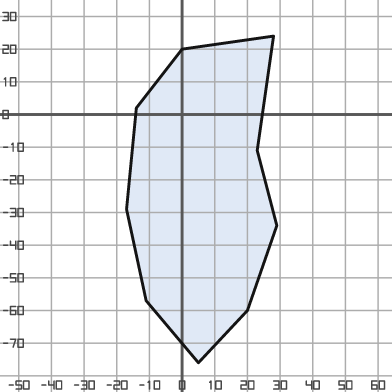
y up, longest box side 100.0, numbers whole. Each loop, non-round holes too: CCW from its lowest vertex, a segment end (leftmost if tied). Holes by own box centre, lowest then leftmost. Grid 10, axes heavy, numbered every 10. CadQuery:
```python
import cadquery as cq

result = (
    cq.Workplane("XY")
    .moveTo(5.0, -76.0)
    .lineTo(20.0, -60.0)
    .lineTo(29.0, -34.0)
    .lineTo(23.0, -11.0)
    .lineTo(28.0, 24.0)
    .lineTo(0.0, 20.0)
    .lineTo(-14.0, 2.0)
    .lineTo(-17.0, -29.0)
    .lineTo(-11.0, -57.0)
    .close()
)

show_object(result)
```